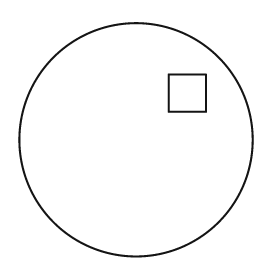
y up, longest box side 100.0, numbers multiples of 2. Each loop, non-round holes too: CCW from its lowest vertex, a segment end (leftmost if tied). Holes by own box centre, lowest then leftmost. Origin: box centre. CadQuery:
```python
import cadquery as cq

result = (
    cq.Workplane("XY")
    .moveTo(0.0, 0.0)
    .circle(50.0)
    .moveTo(14.0, 12.0)
    .lineTo(30.0, 12.0)
    .lineTo(30.0, 28.0)
    .lineTo(14.0, 28.0)
    .close()
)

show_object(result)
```